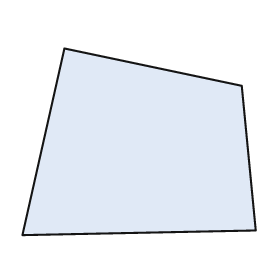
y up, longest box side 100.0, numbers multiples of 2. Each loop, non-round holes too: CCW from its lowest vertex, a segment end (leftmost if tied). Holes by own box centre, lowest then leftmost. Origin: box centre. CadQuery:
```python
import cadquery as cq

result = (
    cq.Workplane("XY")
    .moveTo(-50.0, -40.0)
    .lineTo(50.0, -38.0)
    .lineTo(44.0, 24.0)
    .lineTo(-32.0, 40.0)
    .close()
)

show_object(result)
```